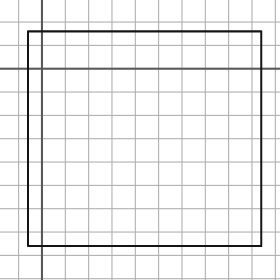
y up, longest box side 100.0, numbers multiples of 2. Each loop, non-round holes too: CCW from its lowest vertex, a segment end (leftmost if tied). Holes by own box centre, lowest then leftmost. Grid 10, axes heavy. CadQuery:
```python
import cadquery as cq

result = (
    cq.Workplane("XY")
    .moveTo(-6.0, -76.0)
    .lineTo(94.0, -76.0)
    .lineTo(94.0, 16.0)
    .lineTo(-6.0, 16.0)
    .close()
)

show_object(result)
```